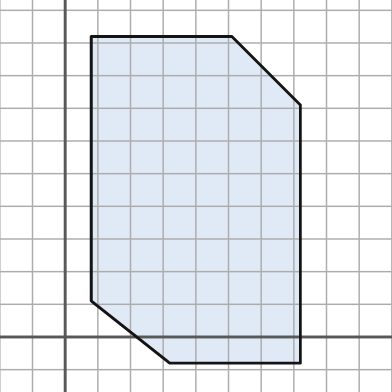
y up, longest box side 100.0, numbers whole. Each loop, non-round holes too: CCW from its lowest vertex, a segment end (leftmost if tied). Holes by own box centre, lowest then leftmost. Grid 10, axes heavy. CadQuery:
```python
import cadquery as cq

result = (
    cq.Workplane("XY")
    .moveTo(32.0, -8.0)
    .lineTo(72.0, -8.0)
    .lineTo(72.0, 71.0)
    .lineTo(51.0, 92.0)
    .lineTo(8.0, 92.0)
    .lineTo(8.0, 11.0)
    .close()
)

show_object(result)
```